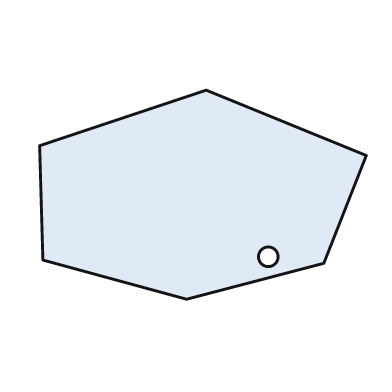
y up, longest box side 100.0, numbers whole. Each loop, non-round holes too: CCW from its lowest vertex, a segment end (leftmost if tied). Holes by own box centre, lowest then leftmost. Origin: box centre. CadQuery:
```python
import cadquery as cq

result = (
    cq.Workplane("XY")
    .moveTo(-5.0, -32.0)
    .lineTo(37.0, -21.0)
    .lineTo(50.0, 12.0)
    .lineTo(1.0, 32.0)
    .lineTo(-50.0, 15.0)
    .lineTo(-49.0, -20.0)
    .close()
    .moveTo(20.0, -19.0)
    .circle(3.0)
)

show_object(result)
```